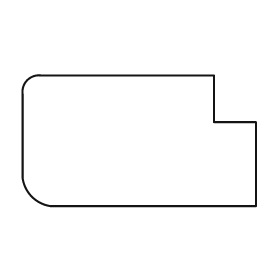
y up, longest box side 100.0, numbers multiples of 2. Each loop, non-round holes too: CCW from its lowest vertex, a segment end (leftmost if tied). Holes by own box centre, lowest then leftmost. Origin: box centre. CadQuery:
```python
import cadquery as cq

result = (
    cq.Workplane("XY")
    .moveTo(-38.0, -28.0)
    .lineTo(50.0, -28.0)
    .lineTo(50.0, 8.0)
    .lineTo(32.0, 8.0)
    .lineTo(32.0, 28.0)
    .lineTo(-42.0, 28.0)
    .threePointArc((-48.0, 26.0), (-50.0, 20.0))
    .lineTo(-50.0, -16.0)
    .threePointArc((-46.0, -24.0), (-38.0, -28.0))
    .close()
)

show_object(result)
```